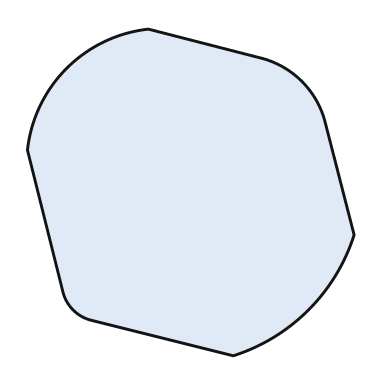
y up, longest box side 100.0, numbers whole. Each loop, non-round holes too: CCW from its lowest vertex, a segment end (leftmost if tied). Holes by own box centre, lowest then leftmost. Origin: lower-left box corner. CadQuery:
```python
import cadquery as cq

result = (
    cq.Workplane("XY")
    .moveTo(63.0, 0.0)
    .threePointArc((86.0, 14.0), (100.0, 37.0))
    .lineTo(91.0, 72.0)
    .threePointArc((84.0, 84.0), (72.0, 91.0))
    .lineTo(37.0, 100.0)
    .threePointArc((12.0, 88.0), (0.0, 63.0))
    .lineTo(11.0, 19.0)
    .threePointArc((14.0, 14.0), (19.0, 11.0))
    .close()
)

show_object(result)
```